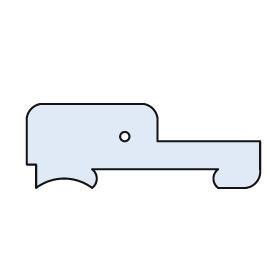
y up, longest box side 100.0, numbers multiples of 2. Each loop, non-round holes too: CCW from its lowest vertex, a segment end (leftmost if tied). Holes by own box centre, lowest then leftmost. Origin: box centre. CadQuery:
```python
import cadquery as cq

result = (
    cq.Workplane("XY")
    .moveTo(-46.0, -18.0)
    .threePointArc((-34.0, -14.0), (-22.0, -18.0))
    .threePointArc((-20.0, -14.0), (-22.0, -10.0))
    .lineTo(32.0, -10.0)
    .threePointArc((30.0, -14.0), (32.0, -18.0))
    .lineTo(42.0, -18.0)
    .threePointArc((48.0, -16.0), (50.0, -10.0))
    .lineTo(50.0, 2.0)
    .lineTo(6.0, 2.0)
    .lineTo(6.0, 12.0)
    .threePointArc((4.0, 16.0), (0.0, 18.0))
    .lineTo(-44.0, 18.0)
    .threePointArc((-48.0, 16.0), (-50.0, 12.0))
    .lineTo(-50.0, -8.0)
    .lineTo(-46.0, -8.0)
    .close()
    .moveTo(-8.0, 4.0)
    .circle(2.0)
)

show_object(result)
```